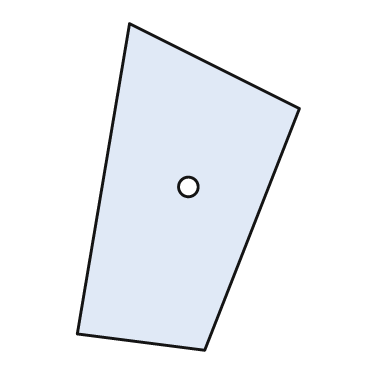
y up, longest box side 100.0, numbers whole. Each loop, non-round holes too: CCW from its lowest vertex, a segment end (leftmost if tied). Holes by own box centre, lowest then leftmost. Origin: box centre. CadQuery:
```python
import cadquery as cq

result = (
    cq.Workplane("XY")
    .moveTo(5.0, -50.0)
    .lineTo(34.0, 24.0)
    .lineTo(-18.0, 50.0)
    .lineTo(-34.0, -45.0)
    .close()
    .moveTo(0.0, 0.0)
    .circle(3.0)
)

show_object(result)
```